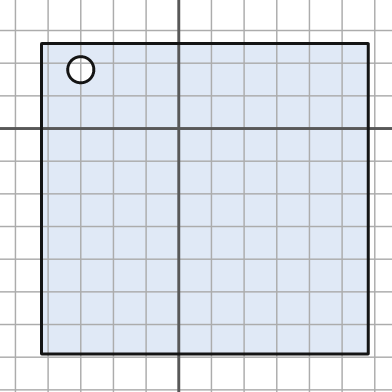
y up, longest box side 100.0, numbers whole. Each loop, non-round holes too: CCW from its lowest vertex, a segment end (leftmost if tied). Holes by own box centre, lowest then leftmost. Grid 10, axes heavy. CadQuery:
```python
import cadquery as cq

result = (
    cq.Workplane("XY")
    .moveTo(-42.0, -69.0)
    .lineTo(58.0, -69.0)
    .lineTo(58.0, 26.0)
    .lineTo(-42.0, 26.0)
    .close()
    .moveTo(-30.0, 18.0)
    .circle(4.0)
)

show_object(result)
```